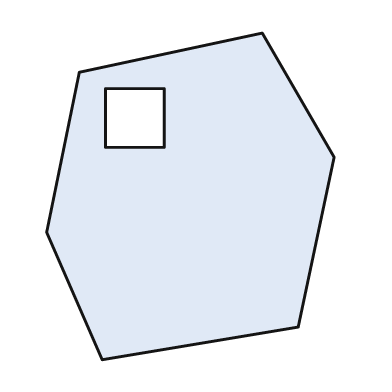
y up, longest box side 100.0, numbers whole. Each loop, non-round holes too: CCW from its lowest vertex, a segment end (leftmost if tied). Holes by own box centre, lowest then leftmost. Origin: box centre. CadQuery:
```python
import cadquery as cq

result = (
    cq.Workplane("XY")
    .moveTo(-27.0, -50.0)
    .lineTo(33.0, -40.0)
    .lineTo(44.0, 12.0)
    .lineTo(22.0, 50.0)
    .lineTo(-34.0, 38.0)
    .lineTo(-44.0, -11.0)
    .close()
    .moveTo(-26.0, 15.0)
    .lineTo(-8.0, 15.0)
    .lineTo(-8.0, 33.0)
    .lineTo(-26.0, 33.0)
    .close()
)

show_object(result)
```